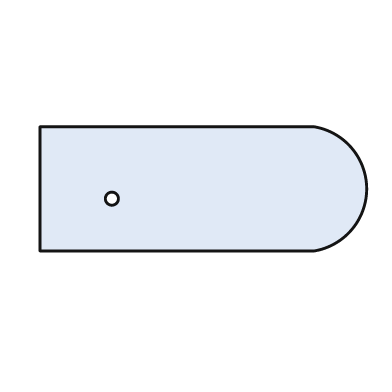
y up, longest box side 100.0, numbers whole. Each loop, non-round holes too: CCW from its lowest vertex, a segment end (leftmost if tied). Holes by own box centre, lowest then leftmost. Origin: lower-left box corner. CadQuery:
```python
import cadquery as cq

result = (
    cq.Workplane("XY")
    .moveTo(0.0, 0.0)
    .lineTo(84.0, 0.0)
    .threePointArc((100.0, 19.0), (84.0, 38.0))
    .lineTo(0.0, 38.0)
    .close()
    .moveTo(22.0, 16.0)
    .circle(2.0)
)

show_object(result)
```